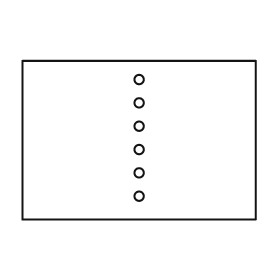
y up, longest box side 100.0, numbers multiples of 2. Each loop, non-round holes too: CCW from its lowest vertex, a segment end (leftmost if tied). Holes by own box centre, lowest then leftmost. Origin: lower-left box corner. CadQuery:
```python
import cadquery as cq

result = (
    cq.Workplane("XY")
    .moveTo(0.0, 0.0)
    .lineTo(100.0, 0.0)
    .lineTo(100.0, 68.0)
    .lineTo(0.0, 68.0)
    .close()
    .moveTo(50.0, 10.0)
    .circle(2.0)
    .moveTo(50.0, 20.0)
    .circle(2.0)
    .moveTo(50.0, 30.0)
    .circle(2.0)
    .moveTo(50.0, 40.0)
    .circle(2.0)
    .moveTo(50.0, 50.0)
    .circle(2.0)
    .moveTo(50.0, 60.0)
    .circle(2.0)
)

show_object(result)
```